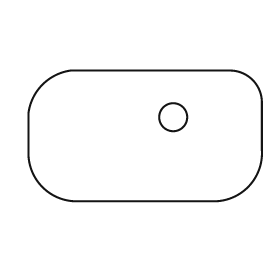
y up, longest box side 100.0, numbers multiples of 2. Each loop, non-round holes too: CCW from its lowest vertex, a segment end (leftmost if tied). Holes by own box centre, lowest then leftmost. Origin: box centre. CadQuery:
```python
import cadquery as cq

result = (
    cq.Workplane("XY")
    .moveTo(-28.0, -28.0)
    .lineTo(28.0, -28.0)
    .threePointArc((44.0, -22.0), (50.0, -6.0))
    .lineTo(50.0, 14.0)
    .threePointArc((46.0, 24.0), (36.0, 28.0))
    .lineTo(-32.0, 28.0)
    .threePointArc((-44.0, 22.0), (-50.0, 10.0))
    .lineTo(-50.0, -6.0)
    .threePointArc((-44.0, -22.0), (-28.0, -28.0))
    .close()
    .moveTo(12.0, 8.0)
    .circle(6.0)
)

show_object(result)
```